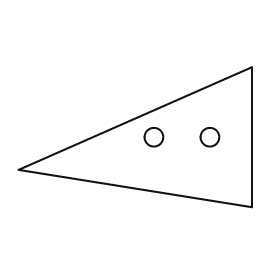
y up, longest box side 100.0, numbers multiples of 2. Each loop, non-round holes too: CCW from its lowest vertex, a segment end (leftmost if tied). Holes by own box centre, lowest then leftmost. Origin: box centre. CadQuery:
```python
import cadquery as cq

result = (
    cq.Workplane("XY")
    .moveTo(50.0, -30.0)
    .lineTo(50.0, 30.0)
    .lineTo(-50.0, -14.0)
    .close()
    .moveTo(8.0, 0.0)
    .circle(4.0)
    .moveTo(32.0, 0.0)
    .circle(4.0)
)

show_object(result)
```